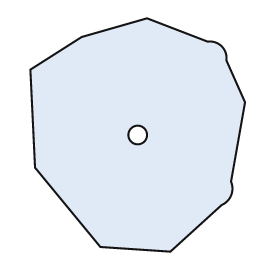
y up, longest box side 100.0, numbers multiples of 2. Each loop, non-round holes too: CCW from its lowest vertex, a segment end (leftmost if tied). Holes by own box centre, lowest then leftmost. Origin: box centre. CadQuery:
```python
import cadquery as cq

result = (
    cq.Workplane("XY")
    .moveTo(14.0, -50.0)
    .lineTo(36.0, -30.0)
    .threePointArc((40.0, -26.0), (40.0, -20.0))
    .lineTo(46.0, 14.0)
    .lineTo(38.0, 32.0)
    .threePointArc((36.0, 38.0), (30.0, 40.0))
    .lineTo(4.0, 50.0)
    .lineTo(-24.0, 42.0)
    .lineTo(-46.0, 28.0)
    .lineTo(-44.0, -14.0)
    .lineTo(-16.0, -48.0)
    .close()
    .moveTo(0.0, 0.0)
    .circle(4.0)
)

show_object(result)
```